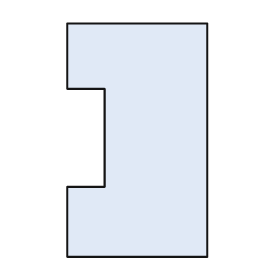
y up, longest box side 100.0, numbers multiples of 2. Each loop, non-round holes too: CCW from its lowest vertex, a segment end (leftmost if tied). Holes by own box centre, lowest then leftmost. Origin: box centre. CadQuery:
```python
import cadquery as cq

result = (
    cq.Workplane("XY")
    .moveTo(-30.0, -50.0)
    .lineTo(30.0, -50.0)
    .lineTo(30.0, 50.0)
    .lineTo(-30.0, 50.0)
    .lineTo(-30.0, 22.0)
    .lineTo(-14.0, 22.0)
    .lineTo(-14.0, -20.0)
    .lineTo(-30.0, -20.0)
    .close()
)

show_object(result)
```